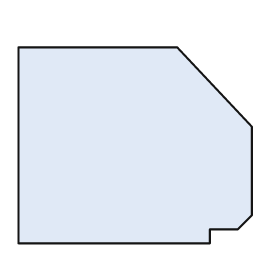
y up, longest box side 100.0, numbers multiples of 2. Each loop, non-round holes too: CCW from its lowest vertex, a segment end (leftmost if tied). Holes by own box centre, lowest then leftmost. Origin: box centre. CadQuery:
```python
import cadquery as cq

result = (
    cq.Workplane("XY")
    .moveTo(-50.0, -42.0)
    .lineTo(32.0, -42.0)
    .lineTo(32.0, -36.0)
    .lineTo(44.0, -36.0)
    .lineTo(50.0, -30.0)
    .lineTo(50.0, 8.0)
    .lineTo(18.0, 42.0)
    .lineTo(-50.0, 42.0)
    .close()
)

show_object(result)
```